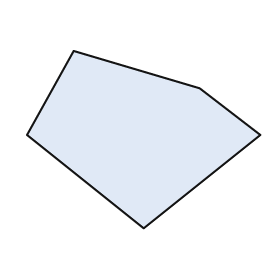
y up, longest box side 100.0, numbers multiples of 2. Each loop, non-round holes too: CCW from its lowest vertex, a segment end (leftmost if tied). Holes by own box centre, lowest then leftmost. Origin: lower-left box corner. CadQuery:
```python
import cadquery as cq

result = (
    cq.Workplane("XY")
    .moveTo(50.0, 0.0)
    .lineTo(100.0, 40.0)
    .lineTo(74.0, 60.0)
    .lineTo(20.0, 76.0)
    .lineTo(0.0, 40.0)
    .close()
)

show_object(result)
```